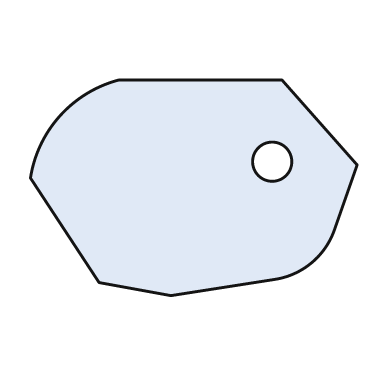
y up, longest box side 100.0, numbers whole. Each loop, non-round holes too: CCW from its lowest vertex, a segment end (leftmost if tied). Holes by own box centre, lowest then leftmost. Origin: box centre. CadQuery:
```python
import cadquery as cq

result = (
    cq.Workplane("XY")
    .moveTo(-7.0, -33.0)
    .lineTo(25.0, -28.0)
    .threePointArc((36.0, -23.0), (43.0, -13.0))
    .lineTo(50.0, 7.0)
    .lineTo(27.0, 33.0)
    .lineTo(-23.0, 33.0)
    .threePointArc((-41.0, 22.0), (-50.0, 3.0))
    .lineTo(-29.0, -29.0)
    .close()
    .moveTo(24.0, 8.0)
    .circle(6.0)
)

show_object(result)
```